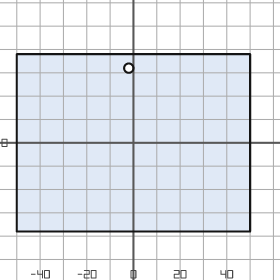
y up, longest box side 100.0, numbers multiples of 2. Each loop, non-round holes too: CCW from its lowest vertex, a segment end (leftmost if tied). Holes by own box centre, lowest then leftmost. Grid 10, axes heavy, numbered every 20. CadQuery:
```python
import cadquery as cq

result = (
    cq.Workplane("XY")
    .moveTo(-50.0, -38.0)
    .lineTo(50.0, -38.0)
    .lineTo(50.0, 38.0)
    .lineTo(-50.0, 38.0)
    .close()
    .moveTo(-2.0, 32.0)
    .circle(2.0)
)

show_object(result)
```